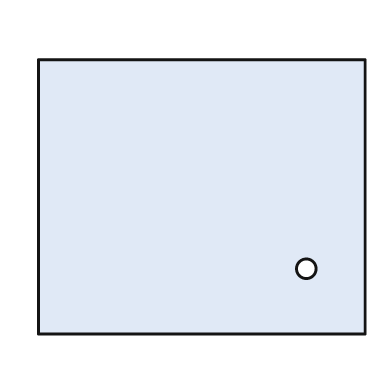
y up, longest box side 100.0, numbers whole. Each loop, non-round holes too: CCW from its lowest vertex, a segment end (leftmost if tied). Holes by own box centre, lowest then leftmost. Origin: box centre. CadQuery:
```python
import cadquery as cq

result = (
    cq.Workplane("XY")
    .moveTo(-50.0, -42.0)
    .lineTo(50.0, -42.0)
    .lineTo(50.0, 42.0)
    .lineTo(-50.0, 42.0)
    .close()
    .moveTo(32.0, -22.0)
    .circle(3.0)
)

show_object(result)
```